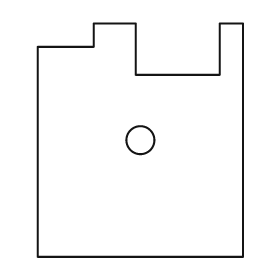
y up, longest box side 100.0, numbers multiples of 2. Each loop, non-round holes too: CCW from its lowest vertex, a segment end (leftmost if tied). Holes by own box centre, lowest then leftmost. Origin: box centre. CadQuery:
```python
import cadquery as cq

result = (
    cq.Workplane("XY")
    .moveTo(-44.0, -50.0)
    .lineTo(44.0, -50.0)
    .lineTo(44.0, 50.0)
    .lineTo(34.0, 50.0)
    .lineTo(34.0, 28.0)
    .lineTo(-2.0, 28.0)
    .lineTo(-2.0, 50.0)
    .lineTo(-20.0, 50.0)
    .lineTo(-20.0, 40.0)
    .lineTo(-44.0, 40.0)
    .close()
    .moveTo(0.0, 0.0)
    .circle(6.0)
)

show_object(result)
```